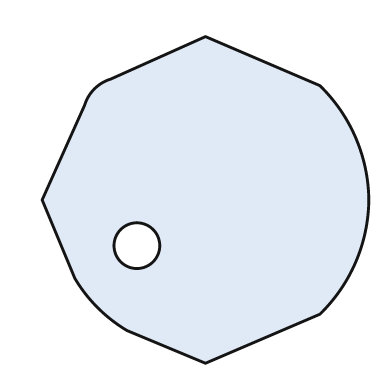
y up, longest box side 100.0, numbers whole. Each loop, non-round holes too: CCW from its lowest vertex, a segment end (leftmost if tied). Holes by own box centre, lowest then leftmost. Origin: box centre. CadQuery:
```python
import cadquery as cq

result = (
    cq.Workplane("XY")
    .moveTo(0.0, -50.0)
    .lineTo(35.0, -35.0)
    .threePointArc((46.0, -19.0), (50.0, 0.0))
    .threePointArc((46.0, 19.0), (35.0, 35.0))
    .lineTo(0.0, 50.0)
    .lineTo(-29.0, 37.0)
    .threePointArc((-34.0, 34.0), (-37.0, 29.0))
    .lineTo(-50.0, 0.0)
    .lineTo(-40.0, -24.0)
    .threePointArc((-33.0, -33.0), (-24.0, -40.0))
    .close()
    .moveTo(-21.0, -14.0)
    .circle(7.0)
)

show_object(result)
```